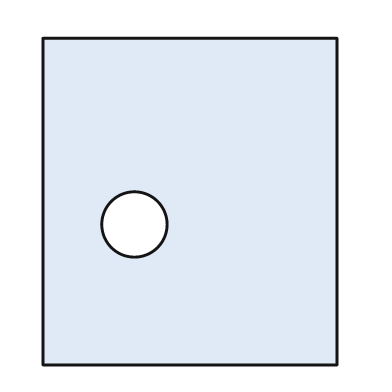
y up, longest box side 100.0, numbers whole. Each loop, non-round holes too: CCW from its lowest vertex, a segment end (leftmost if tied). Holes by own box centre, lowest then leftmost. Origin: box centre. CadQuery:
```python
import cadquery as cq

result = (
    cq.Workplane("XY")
    .moveTo(-45.0, -50.0)
    .lineTo(45.0, -50.0)
    .lineTo(45.0, 50.0)
    .lineTo(-45.0, 50.0)
    .close()
    .moveTo(-17.0, -7.0)
    .circle(10.0)
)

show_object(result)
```